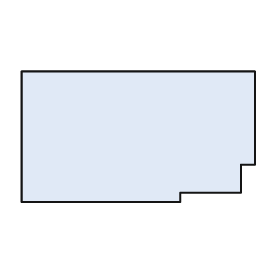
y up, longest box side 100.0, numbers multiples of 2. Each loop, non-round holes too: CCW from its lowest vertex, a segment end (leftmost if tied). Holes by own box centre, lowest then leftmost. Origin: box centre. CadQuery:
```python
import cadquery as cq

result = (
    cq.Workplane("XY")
    .moveTo(-50.0, -28.0)
    .lineTo(18.0, -28.0)
    .lineTo(18.0, -24.0)
    .lineTo(44.0, -24.0)
    .lineTo(44.0, -12.0)
    .lineTo(50.0, -12.0)
    .lineTo(50.0, 28.0)
    .lineTo(-50.0, 28.0)
    .close()
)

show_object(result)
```